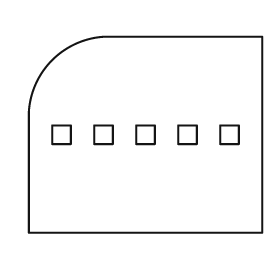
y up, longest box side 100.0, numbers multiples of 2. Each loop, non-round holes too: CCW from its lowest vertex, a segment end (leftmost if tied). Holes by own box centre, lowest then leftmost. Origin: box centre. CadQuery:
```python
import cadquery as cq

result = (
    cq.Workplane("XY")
    .moveTo(-50.0, -42.0)
    .lineTo(50.0, -42.0)
    .lineTo(50.0, 42.0)
    .lineTo(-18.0, 42.0)
    .threePointArc((-40.0, 32.0), (-50.0, 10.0))
    .close()
    .moveTo(-40.0, -4.0)
    .lineTo(-32.0, -4.0)
    .lineTo(-32.0, 4.0)
    .lineTo(-40.0, 4.0)
    .close()
    .moveTo(-22.0, -4.0)
    .lineTo(-14.0, -4.0)
    .lineTo(-14.0, 4.0)
    .lineTo(-22.0, 4.0)
    .close()
    .moveTo(-4.0, -4.0)
    .lineTo(4.0, -4.0)
    .lineTo(4.0, 4.0)
    .lineTo(-4.0, 4.0)
    .close()
    .moveTo(14.0, -4.0)
    .lineTo(22.0, -4.0)
    .lineTo(22.0, 4.0)
    .lineTo(14.0, 4.0)
    .close()
    .moveTo(32.0, -4.0)
    .lineTo(40.0, -4.0)
    .lineTo(40.0, 4.0)
    .lineTo(32.0, 4.0)
    .close()
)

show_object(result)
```